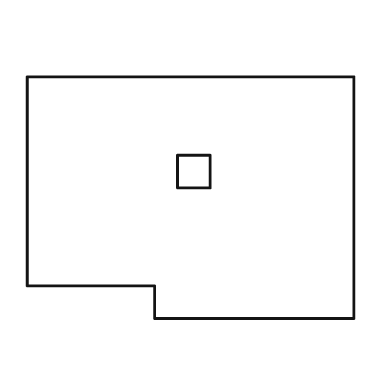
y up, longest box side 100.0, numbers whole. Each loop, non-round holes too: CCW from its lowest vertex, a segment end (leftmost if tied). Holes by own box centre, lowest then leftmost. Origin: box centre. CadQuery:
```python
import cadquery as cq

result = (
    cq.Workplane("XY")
    .moveTo(-11.0, -37.0)
    .lineTo(50.0, -37.0)
    .lineTo(50.0, 37.0)
    .lineTo(-50.0, 37.0)
    .lineTo(-50.0, -27.0)
    .lineTo(-11.0, -27.0)
    .close()
    .moveTo(-4.0, 3.0)
    .lineTo(6.0, 3.0)
    .lineTo(6.0, 13.0)
    .lineTo(-4.0, 13.0)
    .close()
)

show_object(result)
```